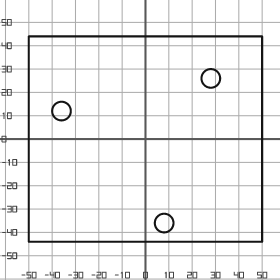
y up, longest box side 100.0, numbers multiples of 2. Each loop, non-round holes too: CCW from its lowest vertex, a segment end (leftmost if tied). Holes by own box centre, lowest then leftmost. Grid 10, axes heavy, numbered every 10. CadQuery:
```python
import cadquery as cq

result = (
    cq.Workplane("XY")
    .moveTo(-50.0, -44.0)
    .lineTo(50.0, -44.0)
    .lineTo(50.0, 44.0)
    .lineTo(-50.0, 44.0)
    .close()
    .moveTo(8.0, -36.0)
    .circle(4.0)
    .moveTo(-36.0, 12.0)
    .circle(4.0)
    .moveTo(28.0, 26.0)
    .circle(4.0)
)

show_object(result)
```